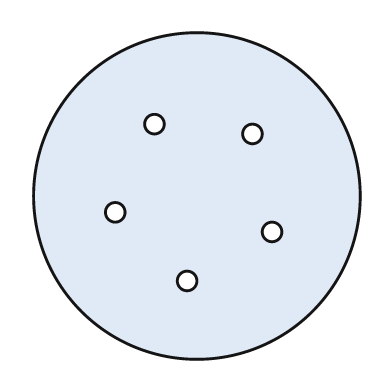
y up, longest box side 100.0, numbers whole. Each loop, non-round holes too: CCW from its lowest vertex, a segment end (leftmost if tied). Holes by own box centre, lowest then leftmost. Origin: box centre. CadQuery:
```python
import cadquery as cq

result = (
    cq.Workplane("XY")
    .moveTo(0.0, 0.0)
    .circle(50.0)
    .moveTo(-3.0, -26.0)
    .circle(3.0)
    .moveTo(23.0, -11.0)
    .circle(3.0)
    .moveTo(-25.0, -5.0)
    .circle(3.0)
    .moveTo(17.0, 19.0)
    .circle(3.0)
    .moveTo(-13.0, 22.0)
    .circle(3.0)
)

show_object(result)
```